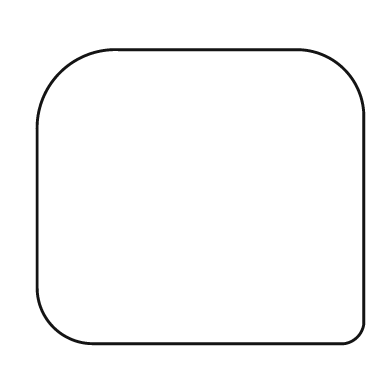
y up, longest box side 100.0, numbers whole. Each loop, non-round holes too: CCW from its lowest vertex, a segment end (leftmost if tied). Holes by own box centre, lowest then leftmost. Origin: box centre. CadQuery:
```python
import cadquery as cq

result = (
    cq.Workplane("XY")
    .moveTo(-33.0, -45.0)
    .lineTo(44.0, -45.0)
    .threePointArc((48.0, -43.0), (50.0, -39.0))
    .lineTo(50.0, 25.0)
    .threePointArc((44.0, 39.0), (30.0, 45.0))
    .lineTo(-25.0, 45.0)
    .threePointArc((-43.0, 38.0), (-50.0, 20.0))
    .lineTo(-50.0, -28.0)
    .threePointArc((-45.0, -40.0), (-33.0, -45.0))
    .close()
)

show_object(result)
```